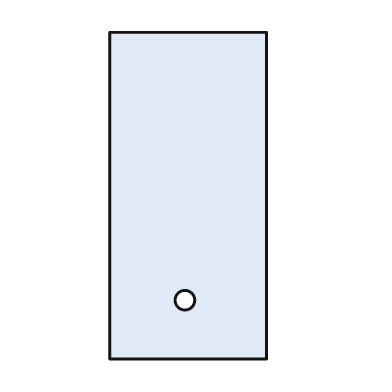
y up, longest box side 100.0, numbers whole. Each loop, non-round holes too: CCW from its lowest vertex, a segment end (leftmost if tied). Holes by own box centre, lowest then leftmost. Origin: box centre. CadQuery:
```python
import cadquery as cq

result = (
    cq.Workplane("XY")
    .moveTo(-24.0, -50.0)
    .lineTo(24.0, -50.0)
    .lineTo(24.0, 50.0)
    .lineTo(-24.0, 50.0)
    .close()
    .moveTo(-1.0, -32.0)
    .circle(3.0)
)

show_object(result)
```